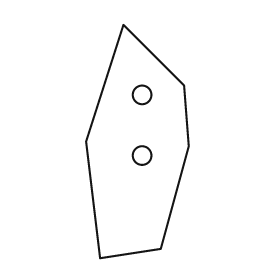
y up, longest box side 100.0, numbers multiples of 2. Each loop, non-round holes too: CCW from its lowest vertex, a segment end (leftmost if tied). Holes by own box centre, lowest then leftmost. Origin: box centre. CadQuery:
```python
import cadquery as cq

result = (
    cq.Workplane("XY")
    .moveTo(-16.0, -50.0)
    .lineTo(10.0, -46.0)
    .lineTo(22.0, -2.0)
    .lineTo(20.0, 24.0)
    .lineTo(-6.0, 50.0)
    .lineTo(-22.0, 0.0)
    .close()
    .moveTo(2.0, -6.0)
    .circle(4.0)
    .moveTo(2.0, 20.0)
    .circle(4.0)
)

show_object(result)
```